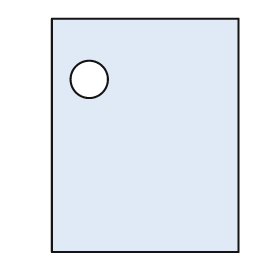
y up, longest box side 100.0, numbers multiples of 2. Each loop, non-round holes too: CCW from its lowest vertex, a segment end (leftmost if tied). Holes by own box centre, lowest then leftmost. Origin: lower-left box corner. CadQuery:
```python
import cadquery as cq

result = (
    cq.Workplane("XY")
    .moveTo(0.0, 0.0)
    .lineTo(80.0, 0.0)
    .lineTo(80.0, 100.0)
    .lineTo(0.0, 100.0)
    .close()
    .moveTo(16.0, 74.0)
    .circle(8.0)
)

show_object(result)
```